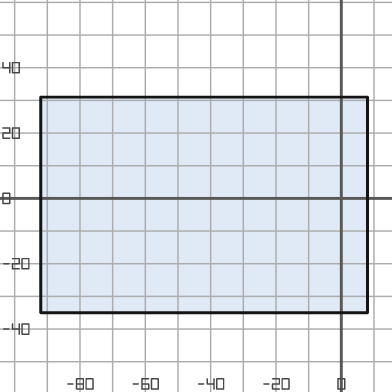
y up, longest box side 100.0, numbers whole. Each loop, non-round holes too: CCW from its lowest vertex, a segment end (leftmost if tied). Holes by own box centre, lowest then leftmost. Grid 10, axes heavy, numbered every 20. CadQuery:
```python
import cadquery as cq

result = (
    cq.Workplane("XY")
    .moveTo(-92.0, -35.0)
    .lineTo(8.0, -35.0)
    .lineTo(8.0, 31.0)
    .lineTo(-92.0, 31.0)
    .close()
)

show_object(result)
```